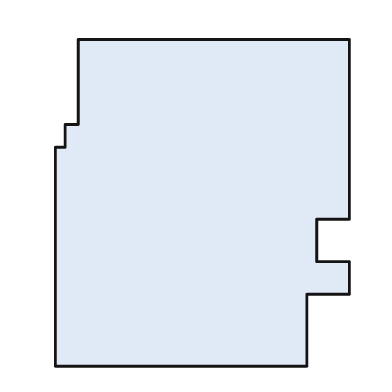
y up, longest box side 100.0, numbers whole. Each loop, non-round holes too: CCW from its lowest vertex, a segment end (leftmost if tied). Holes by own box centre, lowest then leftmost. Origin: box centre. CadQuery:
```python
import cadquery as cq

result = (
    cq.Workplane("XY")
    .moveTo(-45.0, -50.0)
    .lineTo(32.0, -50.0)
    .lineTo(32.0, -28.0)
    .lineTo(45.0, -28.0)
    .lineTo(45.0, -18.0)
    .lineTo(35.0, -18.0)
    .lineTo(35.0, -5.0)
    .lineTo(45.0, -5.0)
    .lineTo(45.0, 50.0)
    .lineTo(-38.0, 50.0)
    .lineTo(-38.0, 24.0)
    .lineTo(-42.0, 24.0)
    .lineTo(-42.0, 17.0)
    .lineTo(-45.0, 17.0)
    .close()
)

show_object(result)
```